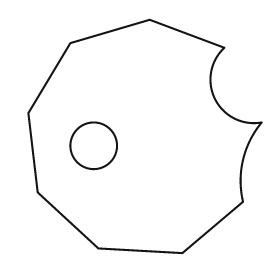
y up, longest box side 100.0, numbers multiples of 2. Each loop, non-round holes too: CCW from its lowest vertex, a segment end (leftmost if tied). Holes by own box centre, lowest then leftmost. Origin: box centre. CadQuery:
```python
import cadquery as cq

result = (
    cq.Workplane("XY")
    .moveTo(16.0, -50.0)
    .lineTo(42.0, -28.0)
    .threePointArc((42.0, -10.0), (50.0, 6.0))
    .threePointArc((30.0, 16.0), (34.0, 38.0))
    .lineTo(2.0, 50.0)
    .lineTo(-32.0, 40.0)
    .lineTo(-50.0, 10.0)
    .lineTo(-46.0, -24.0)
    .lineTo(-20.0, -48.0)
    .close()
    .moveTo(-22.0, -4.0)
    .circle(10.0)
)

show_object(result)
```